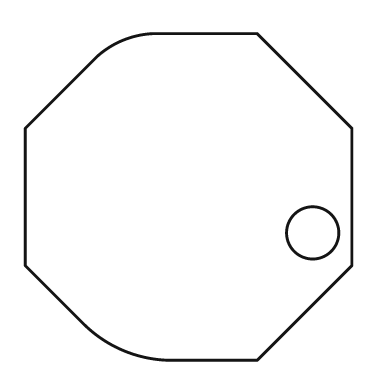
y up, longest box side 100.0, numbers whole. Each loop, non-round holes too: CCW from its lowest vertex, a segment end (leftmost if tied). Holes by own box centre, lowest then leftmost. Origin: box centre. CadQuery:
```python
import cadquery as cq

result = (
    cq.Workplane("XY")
    .moveTo(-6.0, -50.0)
    .lineTo(21.0, -50.0)
    .lineTo(50.0, -21.0)
    .lineTo(50.0, 21.0)
    .lineTo(21.0, 50.0)
    .lineTo(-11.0, 50.0)
    .threePointArc((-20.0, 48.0), (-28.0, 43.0))
    .lineTo(-50.0, 21.0)
    .lineTo(-50.0, -21.0)
    .lineTo(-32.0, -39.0)
    .threePointArc((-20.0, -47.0), (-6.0, -50.0))
    .close()
    .moveTo(38.0, -11.0)
    .circle(8.0)
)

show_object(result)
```